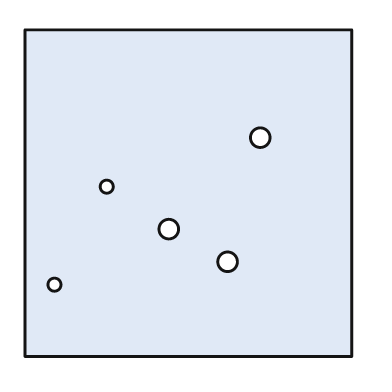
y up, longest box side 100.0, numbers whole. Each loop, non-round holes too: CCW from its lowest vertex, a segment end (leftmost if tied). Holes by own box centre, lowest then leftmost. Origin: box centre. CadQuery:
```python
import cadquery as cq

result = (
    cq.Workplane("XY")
    .moveTo(-50.0, -50.0)
    .lineTo(50.0, -50.0)
    .lineTo(50.0, 50.0)
    .lineTo(-50.0, 50.0)
    .close()
    .moveTo(-41.0, -28.0)
    .circle(2.0)
    .moveTo(12.0, -21.0)
    .circle(3.0)
    .moveTo(-6.0, -11.0)
    .circle(3.0)
    .moveTo(-25.0, 2.0)
    .circle(2.0)
    .moveTo(22.0, 17.0)
    .circle(3.0)
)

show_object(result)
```